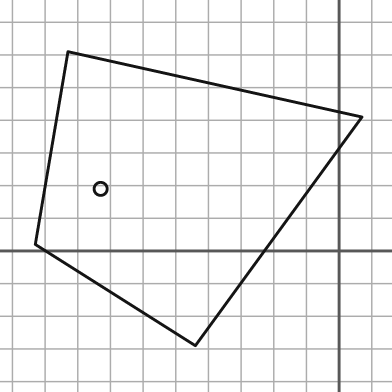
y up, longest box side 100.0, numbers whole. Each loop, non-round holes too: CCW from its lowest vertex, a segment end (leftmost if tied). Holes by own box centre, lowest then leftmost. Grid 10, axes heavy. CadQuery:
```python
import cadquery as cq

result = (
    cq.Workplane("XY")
    .moveTo(-44.0, -29.0)
    .lineTo(7.0, 41.0)
    .lineTo(-83.0, 61.0)
    .lineTo(-93.0, 2.0)
    .close()
    .moveTo(-73.0, 19.0)
    .circle(2.0)
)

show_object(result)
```